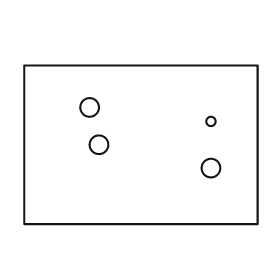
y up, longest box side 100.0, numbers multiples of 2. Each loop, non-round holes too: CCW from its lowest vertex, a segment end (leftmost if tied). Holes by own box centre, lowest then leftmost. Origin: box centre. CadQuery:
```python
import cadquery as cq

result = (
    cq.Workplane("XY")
    .moveTo(-50.0, -34.0)
    .lineTo(50.0, -34.0)
    .lineTo(50.0, 34.0)
    .lineTo(-50.0, 34.0)
    .close()
    .moveTo(30.0, -10.0)
    .circle(4.0)
    .moveTo(-18.0, 0.0)
    .circle(4.0)
    .moveTo(30.0, 10.0)
    .circle(2.0)
    .moveTo(-22.0, 16.0)
    .circle(4.0)
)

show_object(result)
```